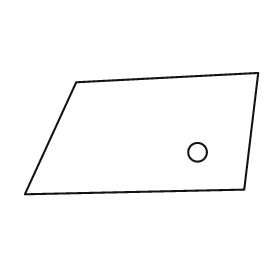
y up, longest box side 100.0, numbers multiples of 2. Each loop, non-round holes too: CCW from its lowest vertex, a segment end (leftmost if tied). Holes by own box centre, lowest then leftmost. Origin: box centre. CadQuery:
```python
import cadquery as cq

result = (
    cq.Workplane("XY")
    .moveTo(-50.0, -26.0)
    .lineTo(44.0, -24.0)
    .lineTo(50.0, 26.0)
    .lineTo(-28.0, 22.0)
    .close()
    .moveTo(24.0, -8.0)
    .circle(4.0)
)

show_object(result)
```